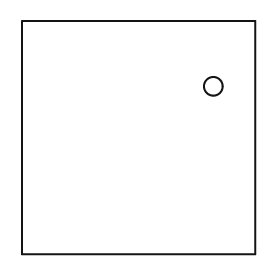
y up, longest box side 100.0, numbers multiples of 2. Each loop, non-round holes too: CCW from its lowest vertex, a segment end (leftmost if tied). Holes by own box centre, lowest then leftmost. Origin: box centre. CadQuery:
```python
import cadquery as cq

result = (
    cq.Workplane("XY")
    .moveTo(-50.0, -50.0)
    .lineTo(50.0, -50.0)
    .lineTo(50.0, 50.0)
    .lineTo(-50.0, 50.0)
    .close()
    .moveTo(32.0, 22.0)
    .circle(4.0)
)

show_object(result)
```